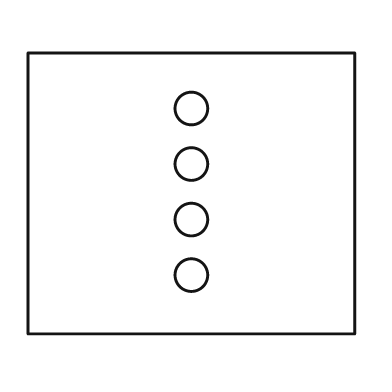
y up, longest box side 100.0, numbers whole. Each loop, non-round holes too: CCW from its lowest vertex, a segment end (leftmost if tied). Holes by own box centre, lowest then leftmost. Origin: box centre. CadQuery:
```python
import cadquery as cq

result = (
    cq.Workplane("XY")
    .moveTo(-50.0, -43.0)
    .lineTo(50.0, -43.0)
    .lineTo(50.0, 43.0)
    .lineTo(-50.0, 43.0)
    .close()
    .moveTo(0.0, -25.0)
    .circle(5.0)
    .moveTo(0.0, -8.0)
    .circle(5.0)
    .moveTo(0.0, 9.0)
    .circle(5.0)
    .moveTo(0.0, 26.0)
    .circle(5.0)
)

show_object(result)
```